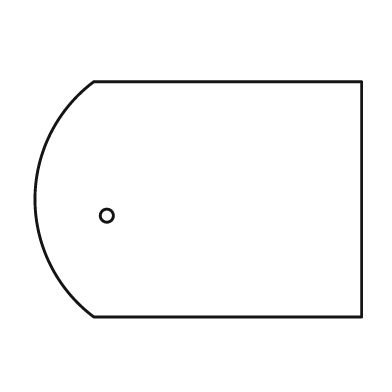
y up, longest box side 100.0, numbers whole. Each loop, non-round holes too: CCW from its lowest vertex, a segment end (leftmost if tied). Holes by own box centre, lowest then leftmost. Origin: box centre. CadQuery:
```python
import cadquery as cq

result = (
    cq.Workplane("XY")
    .moveTo(-32.0, -36.0)
    .lineTo(50.0, -36.0)
    .lineTo(50.0, 36.0)
    .lineTo(-32.0, 36.0)
    .threePointArc((-50.0, 0.0), (-32.0, -36.0))
    .close()
    .moveTo(-28.0, -5.0)
    .circle(2.0)
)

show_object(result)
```